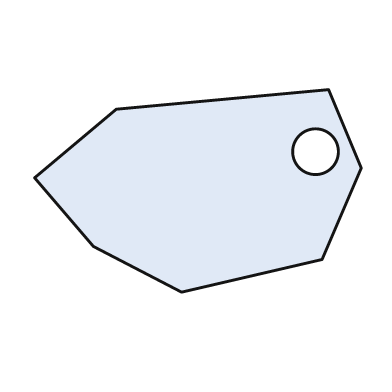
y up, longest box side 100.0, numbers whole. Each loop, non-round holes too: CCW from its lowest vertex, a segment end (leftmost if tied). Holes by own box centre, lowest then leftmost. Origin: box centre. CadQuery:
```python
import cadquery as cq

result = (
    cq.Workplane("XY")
    .moveTo(-5.0, -31.0)
    .lineTo(38.0, -21.0)
    .lineTo(50.0, 7.0)
    .lineTo(40.0, 31.0)
    .lineTo(-25.0, 25.0)
    .lineTo(-50.0, 4.0)
    .lineTo(-32.0, -17.0)
    .close()
    .moveTo(36.0, 12.0)
    .circle(7.0)
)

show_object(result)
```